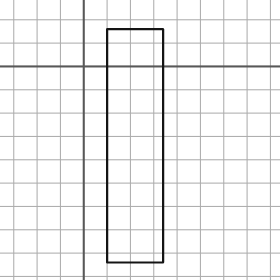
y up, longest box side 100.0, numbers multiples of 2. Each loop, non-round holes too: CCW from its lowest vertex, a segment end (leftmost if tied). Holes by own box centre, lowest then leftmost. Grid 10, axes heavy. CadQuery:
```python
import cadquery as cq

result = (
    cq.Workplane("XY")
    .moveTo(10.0, -84.0)
    .lineTo(34.0, -84.0)
    .lineTo(34.0, 16.0)
    .lineTo(10.0, 16.0)
    .close()
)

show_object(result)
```